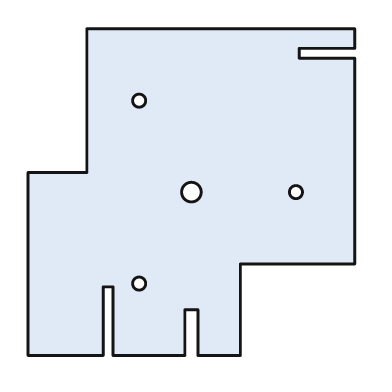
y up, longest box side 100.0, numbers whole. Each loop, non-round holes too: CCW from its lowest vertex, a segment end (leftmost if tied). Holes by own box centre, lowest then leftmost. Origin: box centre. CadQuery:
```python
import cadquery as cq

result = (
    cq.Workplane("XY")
    .moveTo(-50.0, -50.0)
    .lineTo(-27.0, -50.0)
    .lineTo(-27.0, -29.0)
    .lineTo(-24.0, -29.0)
    .lineTo(-24.0, -50.0)
    .lineTo(-2.0, -50.0)
    .lineTo(-2.0, -36.0)
    .lineTo(2.0, -36.0)
    .lineTo(2.0, -50.0)
    .lineTo(15.0, -50.0)
    .lineTo(15.0, -22.0)
    .lineTo(50.0, -22.0)
    .lineTo(50.0, 41.0)
    .lineTo(33.0, 41.0)
    .lineTo(33.0, 44.0)
    .lineTo(50.0, 44.0)
    .lineTo(50.0, 50.0)
    .lineTo(-32.0, 50.0)
    .lineTo(-32.0, 6.0)
    .lineTo(-50.0, 6.0)
    .close()
    .moveTo(-16.0, -28.0)
    .circle(2.0)
    .moveTo(0.0, 0.0)
    .circle(3.0)
    .moveTo(32.0, 0.0)
    .circle(2.0)
    .moveTo(-16.0, 28.0)
    .circle(2.0)
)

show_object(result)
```